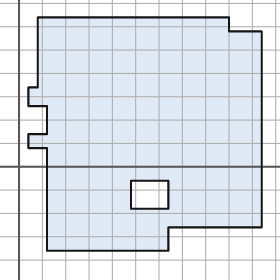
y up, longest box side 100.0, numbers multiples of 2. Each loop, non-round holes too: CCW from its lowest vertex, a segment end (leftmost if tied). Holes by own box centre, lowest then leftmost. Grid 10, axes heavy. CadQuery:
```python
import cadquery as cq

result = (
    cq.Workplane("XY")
    .moveTo(12.0, -36.0)
    .lineTo(64.0, -36.0)
    .lineTo(64.0, -26.0)
    .lineTo(104.0, -26.0)
    .lineTo(104.0, 58.0)
    .lineTo(90.0, 58.0)
    .lineTo(90.0, 64.0)
    .lineTo(8.0, 64.0)
    .lineTo(8.0, 34.0)
    .lineTo(4.0, 34.0)
    .lineTo(4.0, 26.0)
    .lineTo(12.0, 26.0)
    .lineTo(12.0, 14.0)
    .lineTo(4.0, 14.0)
    .lineTo(4.0, 8.0)
    .lineTo(12.0, 8.0)
    .close()
    .moveTo(48.0, -18.0)
    .lineTo(64.0, -18.0)
    .lineTo(64.0, -6.0)
    .lineTo(48.0, -6.0)
    .close()
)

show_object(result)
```